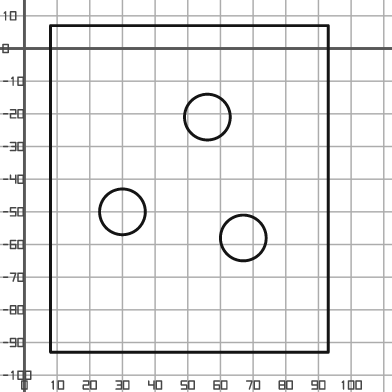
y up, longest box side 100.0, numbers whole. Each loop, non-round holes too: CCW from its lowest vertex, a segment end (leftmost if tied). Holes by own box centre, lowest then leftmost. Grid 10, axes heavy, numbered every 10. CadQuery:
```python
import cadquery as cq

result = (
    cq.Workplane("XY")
    .moveTo(8.0, -93.0)
    .lineTo(93.0, -93.0)
    .lineTo(93.0, 7.0)
    .lineTo(8.0, 7.0)
    .close()
    .moveTo(67.0, -58.0)
    .circle(7.0)
    .moveTo(30.0, -50.0)
    .circle(7.0)
    .moveTo(56.0, -21.0)
    .circle(7.0)
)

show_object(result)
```